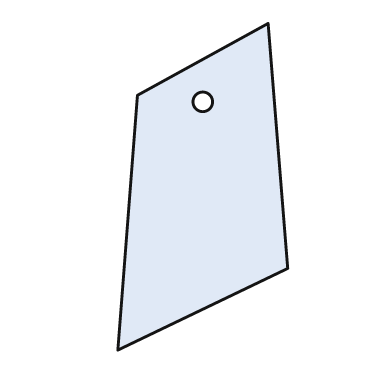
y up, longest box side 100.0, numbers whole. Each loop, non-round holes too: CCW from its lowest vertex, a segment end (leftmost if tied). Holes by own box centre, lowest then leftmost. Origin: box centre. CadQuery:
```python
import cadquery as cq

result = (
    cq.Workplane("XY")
    .moveTo(-26.0, -50.0)
    .lineTo(26.0, -25.0)
    .lineTo(20.0, 50.0)
    .lineTo(-20.0, 28.0)
    .close()
    .moveTo(0.0, 26.0)
    .circle(3.0)
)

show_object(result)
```